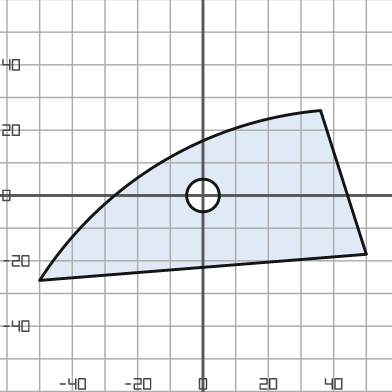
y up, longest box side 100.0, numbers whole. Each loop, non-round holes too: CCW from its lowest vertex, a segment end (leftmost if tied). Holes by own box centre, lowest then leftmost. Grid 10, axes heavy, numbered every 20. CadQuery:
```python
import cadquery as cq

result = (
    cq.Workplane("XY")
    .moveTo(-50.0, -26.0)
    .lineTo(50.0, -18.0)
    .lineTo(36.0, 26.0)
    .threePointArc((-13.0, 10.0), (-50.0, -26.0))
    .close()
    .moveTo(0.0, 0.0)
    .circle(5.0)
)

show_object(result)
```